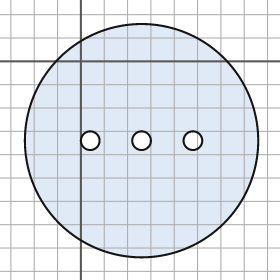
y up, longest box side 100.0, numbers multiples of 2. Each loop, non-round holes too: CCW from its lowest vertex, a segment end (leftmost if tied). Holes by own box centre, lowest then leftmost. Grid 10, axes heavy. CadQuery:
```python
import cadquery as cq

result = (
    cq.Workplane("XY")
    .moveTo(26.0, -34.0)
    .circle(50.0)
    .moveTo(4.0, -34.0)
    .circle(4.0)
    .moveTo(26.0, -34.0)
    .circle(4.0)
    .moveTo(48.0, -34.0)
    .circle(4.0)
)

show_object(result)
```